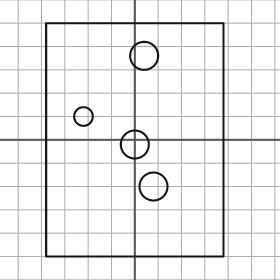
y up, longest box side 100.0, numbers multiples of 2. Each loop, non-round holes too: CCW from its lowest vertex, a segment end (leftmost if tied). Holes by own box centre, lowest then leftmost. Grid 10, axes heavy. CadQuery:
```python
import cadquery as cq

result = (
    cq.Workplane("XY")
    .moveTo(-38.0, -50.0)
    .lineTo(38.0, -50.0)
    .lineTo(38.0, 50.0)
    .lineTo(-38.0, 50.0)
    .close()
    .moveTo(8.0, -20.0)
    .circle(6.0)
    .moveTo(0.0, -2.0)
    .circle(6.0)
    .moveTo(-22.0, 10.0)
    .circle(4.0)
    .moveTo(4.0, 36.0)
    .circle(6.0)
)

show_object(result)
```